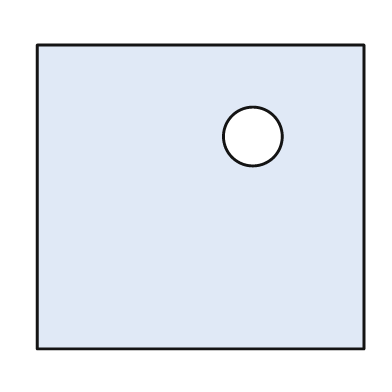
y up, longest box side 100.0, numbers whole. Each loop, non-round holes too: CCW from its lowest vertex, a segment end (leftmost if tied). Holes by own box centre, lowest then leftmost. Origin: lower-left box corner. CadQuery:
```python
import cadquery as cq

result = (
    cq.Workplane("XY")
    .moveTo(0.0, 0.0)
    .lineTo(100.0, 0.0)
    .lineTo(100.0, 93.0)
    .lineTo(0.0, 93.0)
    .close()
    .moveTo(66.0, 65.0)
    .circle(9.0)
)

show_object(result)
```